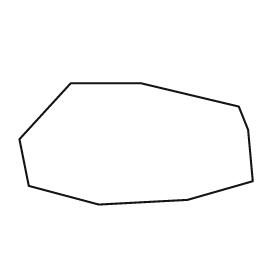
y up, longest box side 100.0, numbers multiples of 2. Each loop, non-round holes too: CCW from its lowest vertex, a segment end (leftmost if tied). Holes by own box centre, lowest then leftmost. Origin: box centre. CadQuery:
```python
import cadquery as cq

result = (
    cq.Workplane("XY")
    .moveTo(-16.0, -26.0)
    .lineTo(22.0, -24.0)
    .lineTo(50.0, -16.0)
    .lineTo(48.0, 6.0)
    .lineTo(44.0, 16.0)
    .lineTo(2.0, 26.0)
    .lineTo(-28.0, 26.0)
    .lineTo(-50.0, 2.0)
    .lineTo(-46.0, -18.0)
    .close()
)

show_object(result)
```